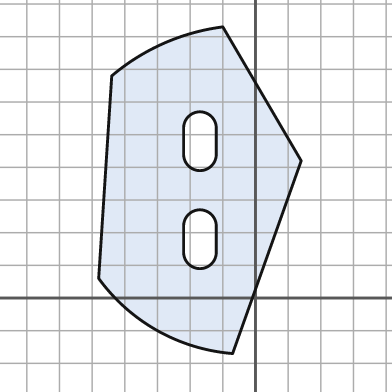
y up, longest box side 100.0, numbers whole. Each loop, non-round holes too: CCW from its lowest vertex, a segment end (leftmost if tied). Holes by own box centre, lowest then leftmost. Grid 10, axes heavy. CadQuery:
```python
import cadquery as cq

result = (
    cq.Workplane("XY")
    .moveTo(-7.0, -17.0)
    .lineTo(14.0, 42.0)
    .lineTo(-10.0, 83.0)
    .threePointArc((-28.0, 78.0), (-44.0, 68.0))
    .lineTo(-48.0, 6.0)
    .threePointArc((-30.0, -10.0), (-7.0, -17.0))
    .close()
    .moveTo(-22.0, 14.0)
    .threePointArc((-17.0, 9.0), (-12.0, 14.0))
    .lineTo(-12.0, 22.0)
    .threePointArc((-17.0, 27.0), (-22.0, 22.0))
    .close()
    .moveTo(-22.0, 44.0)
    .threePointArc((-17.0, 39.0), (-12.0, 44.0))
    .lineTo(-12.0, 52.0)
    .threePointArc((-17.0, 57.0), (-22.0, 52.0))
    .close()
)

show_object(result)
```